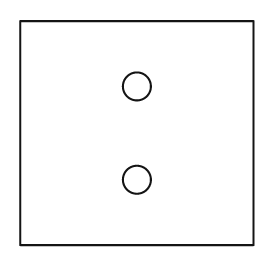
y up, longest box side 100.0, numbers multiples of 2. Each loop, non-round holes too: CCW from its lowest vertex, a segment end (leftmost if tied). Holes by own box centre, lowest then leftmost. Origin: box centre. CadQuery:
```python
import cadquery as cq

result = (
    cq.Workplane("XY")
    .moveTo(-50.0, -48.0)
    .lineTo(50.0, -48.0)
    .lineTo(50.0, 48.0)
    .lineTo(-50.0, 48.0)
    .close()
    .moveTo(0.0, -20.0)
    .circle(6.0)
    .moveTo(0.0, 20.0)
    .circle(6.0)
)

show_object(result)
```